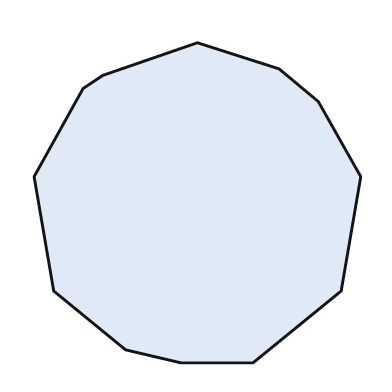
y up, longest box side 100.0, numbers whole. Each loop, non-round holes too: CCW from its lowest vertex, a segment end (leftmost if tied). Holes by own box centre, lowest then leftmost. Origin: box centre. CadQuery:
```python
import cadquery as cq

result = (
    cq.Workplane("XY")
    .moveTo(-5.0, -49.0)
    .lineTo(17.0, -49.0)
    .lineTo(44.0, -27.0)
    .lineTo(50.0, 8.0)
    .lineTo(37.0, 31.0)
    .lineTo(25.0, 41.0)
    .lineTo(0.0, 49.0)
    .lineTo(-29.0, 39.0)
    .lineTo(-35.0, 35.0)
    .lineTo(-50.0, 8.0)
    .lineTo(-44.0, -27.0)
    .lineTo(-22.0, -45.0)
    .close()
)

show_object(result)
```